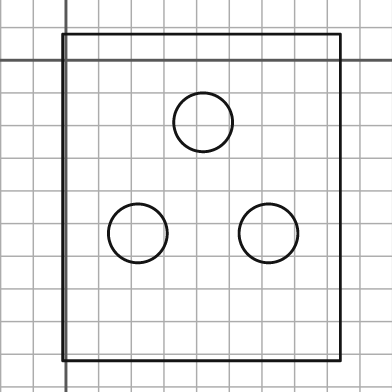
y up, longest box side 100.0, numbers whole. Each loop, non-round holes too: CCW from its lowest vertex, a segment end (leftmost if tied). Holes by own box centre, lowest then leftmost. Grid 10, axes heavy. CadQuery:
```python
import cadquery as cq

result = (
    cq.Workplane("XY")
    .moveTo(-1.0, -92.0)
    .lineTo(84.0, -92.0)
    .lineTo(84.0, 8.0)
    .lineTo(-1.0, 8.0)
    .close()
    .moveTo(22.0, -53.0)
    .circle(9.0)
    .moveTo(62.0, -53.0)
    .circle(9.0)
    .moveTo(42.0, -19.0)
    .circle(9.0)
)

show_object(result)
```